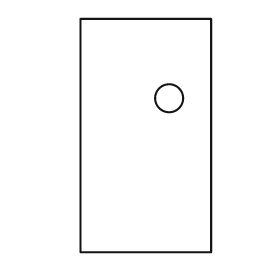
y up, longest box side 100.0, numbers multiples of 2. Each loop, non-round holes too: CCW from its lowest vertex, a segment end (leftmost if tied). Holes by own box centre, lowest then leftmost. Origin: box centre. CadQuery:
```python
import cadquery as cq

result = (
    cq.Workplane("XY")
    .moveTo(-28.0, -50.0)
    .lineTo(28.0, -50.0)
    .lineTo(28.0, 50.0)
    .lineTo(-28.0, 50.0)
    .close()
    .moveTo(10.0, 16.0)
    .circle(6.0)
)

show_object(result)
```